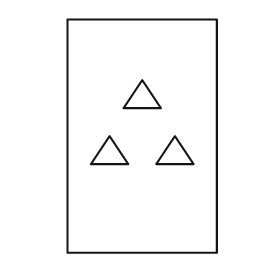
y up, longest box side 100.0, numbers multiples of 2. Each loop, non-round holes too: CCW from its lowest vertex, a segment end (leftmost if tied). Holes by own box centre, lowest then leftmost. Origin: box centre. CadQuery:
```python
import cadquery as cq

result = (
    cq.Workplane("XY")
    .moveTo(-32.0, -50.0)
    .lineTo(32.0, -50.0)
    .lineTo(32.0, 50.0)
    .lineTo(-32.0, 50.0)
    .close()
    .moveTo(-22.0, -12.0)
    .lineTo(-6.0, -12.0)
    .lineTo(-14.0, 0.0)
    .close()
    .moveTo(6.0, -12.0)
    .lineTo(22.0, -12.0)
    .lineTo(14.0, 0.0)
    .close()
    .moveTo(-8.0, 12.0)
    .lineTo(8.0, 12.0)
    .lineTo(0.0, 24.0)
    .close()
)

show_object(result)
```